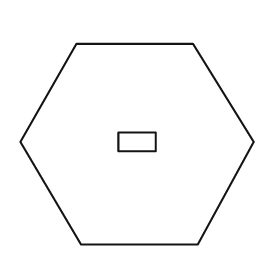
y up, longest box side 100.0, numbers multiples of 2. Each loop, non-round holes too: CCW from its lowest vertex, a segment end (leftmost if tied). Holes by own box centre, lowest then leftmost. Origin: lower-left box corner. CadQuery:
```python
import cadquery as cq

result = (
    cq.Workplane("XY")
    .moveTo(26.0, 0.0)
    .lineTo(76.0, 0.0)
    .lineTo(100.0, 44.0)
    .lineTo(74.0, 86.0)
    .lineTo(24.0, 86.0)
    .lineTo(0.0, 44.0)
    .close()
    .moveTo(42.0, 40.0)
    .lineTo(58.0, 40.0)
    .lineTo(58.0, 48.0)
    .lineTo(42.0, 48.0)
    .close()
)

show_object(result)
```